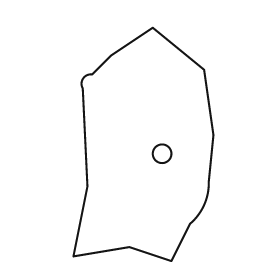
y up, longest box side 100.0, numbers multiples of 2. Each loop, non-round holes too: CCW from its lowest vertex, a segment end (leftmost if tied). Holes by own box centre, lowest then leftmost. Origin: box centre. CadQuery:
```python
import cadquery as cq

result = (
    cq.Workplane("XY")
    .moveTo(12.0, -50.0)
    .lineTo(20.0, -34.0)
    .threePointArc((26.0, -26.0), (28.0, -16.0))
    .lineTo(30.0, 4.0)
    .lineTo(26.0, 32.0)
    .lineTo(4.0, 50.0)
    .lineTo(-14.0, 38.0)
    .lineTo(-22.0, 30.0)
    .threePointArc((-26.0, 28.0), (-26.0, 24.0))
    .lineTo(-24.0, -18.0)
    .lineTo(-30.0, -48.0)
    .lineTo(-6.0, -44.0)
    .close()
    .moveTo(8.0, -4.0)
    .circle(4.0)
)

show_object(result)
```